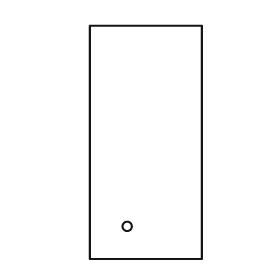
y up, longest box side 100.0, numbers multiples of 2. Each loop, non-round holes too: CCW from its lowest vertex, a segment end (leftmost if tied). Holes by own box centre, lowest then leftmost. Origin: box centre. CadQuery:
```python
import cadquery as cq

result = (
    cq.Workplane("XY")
    .moveTo(-24.0, -50.0)
    .lineTo(24.0, -50.0)
    .lineTo(24.0, 50.0)
    .lineTo(-24.0, 50.0)
    .close()
    .moveTo(-8.0, -36.0)
    .circle(2.0)
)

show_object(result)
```